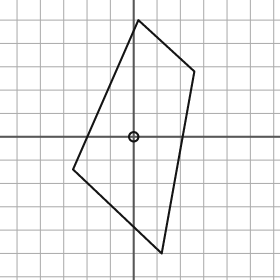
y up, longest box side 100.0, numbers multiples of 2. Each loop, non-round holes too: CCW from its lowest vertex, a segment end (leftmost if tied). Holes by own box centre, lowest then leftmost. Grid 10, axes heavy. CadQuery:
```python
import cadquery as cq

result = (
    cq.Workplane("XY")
    .moveTo(12.0, -50.0)
    .lineTo(26.0, 28.0)
    .lineTo(2.0, 50.0)
    .lineTo(-26.0, -14.0)
    .close()
    .moveTo(0.0, 0.0)
    .circle(2.0)
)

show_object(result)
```